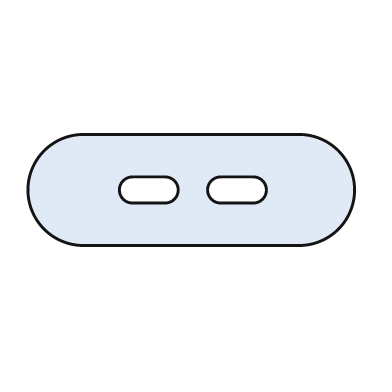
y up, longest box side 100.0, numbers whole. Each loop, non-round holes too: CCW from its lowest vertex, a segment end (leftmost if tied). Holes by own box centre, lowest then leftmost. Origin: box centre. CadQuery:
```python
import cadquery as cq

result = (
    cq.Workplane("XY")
    .moveTo(-33.0, -17.0)
    .lineTo(33.0, -17.0)
    .threePointArc((50.0, 0.0), (33.0, 17.0))
    .lineTo(-33.0, 17.0)
    .threePointArc((-50.0, 0.0), (-33.0, -17.0))
    .close()
    .moveTo(-18.0, -4.0)
    .lineTo(-8.0, -4.0)
    .threePointArc((-4.0, 0.0), (-8.0, 4.0))
    .lineTo(-18.0, 4.0)
    .threePointArc((-22.0, 0.0), (-18.0, -4.0))
    .close()
    .moveTo(9.0, -4.0)
    .lineTo(19.0, -4.0)
    .threePointArc((23.0, 0.0), (19.0, 4.0))
    .lineTo(9.0, 4.0)
    .threePointArc((5.0, 0.0), (9.0, -4.0))
    .close()
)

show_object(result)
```